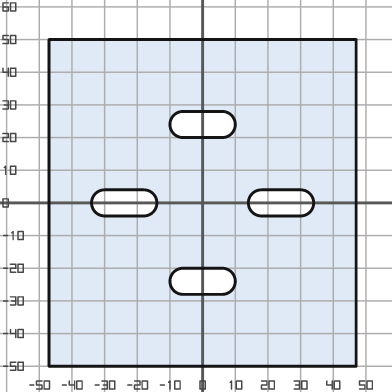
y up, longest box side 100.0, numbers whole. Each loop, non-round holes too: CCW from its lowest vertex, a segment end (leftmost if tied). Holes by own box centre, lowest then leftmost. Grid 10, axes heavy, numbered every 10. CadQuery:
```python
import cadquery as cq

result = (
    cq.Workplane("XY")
    .moveTo(-47.0, -50.0)
    .lineTo(47.0, -50.0)
    .lineTo(47.0, 50.0)
    .lineTo(-47.0, 50.0)
    .close()
    .moveTo(-6.0, -28.0)
    .lineTo(6.0, -28.0)
    .threePointArc((10.0, -24.0), (6.0, -20.0))
    .lineTo(-6.0, -20.0)
    .threePointArc((-10.0, -24.0), (-6.0, -28.0))
    .close()
    .moveTo(-30.0, -4.0)
    .lineTo(-18.0, -4.0)
    .threePointArc((-14.0, 0.0), (-18.0, 4.0))
    .lineTo(-30.0, 4.0)
    .threePointArc((-34.0, 0.0), (-30.0, -4.0))
    .close()
    .moveTo(18.0, -4.0)
    .lineTo(30.0, -4.0)
    .threePointArc((34.0, 0.0), (30.0, 4.0))
    .lineTo(18.0, 4.0)
    .threePointArc((14.0, 0.0), (18.0, -4.0))
    .close()
    .moveTo(-6.0, 20.0)
    .lineTo(6.0, 20.0)
    .threePointArc((10.0, 24.0), (6.0, 28.0))
    .lineTo(-6.0, 28.0)
    .threePointArc((-10.0, 24.0), (-6.0, 20.0))
    .close()
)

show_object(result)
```